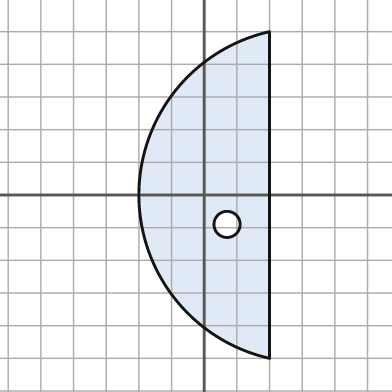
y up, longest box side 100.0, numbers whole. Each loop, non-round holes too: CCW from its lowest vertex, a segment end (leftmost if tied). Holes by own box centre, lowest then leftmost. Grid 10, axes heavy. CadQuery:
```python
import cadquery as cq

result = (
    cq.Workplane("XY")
    .moveTo(20.0, -50.0)
    .lineTo(20.0, 50.0)
    .threePointArc((-20.0, 0.0), (20.0, -50.0))
    .close()
    .moveTo(7.0, -9.0)
    .circle(4.0)
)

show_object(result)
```